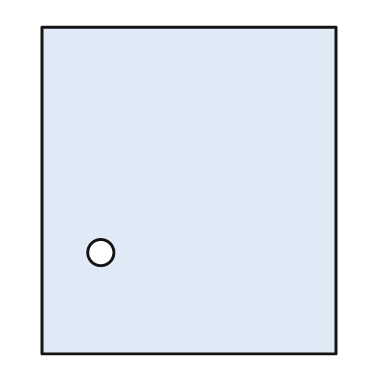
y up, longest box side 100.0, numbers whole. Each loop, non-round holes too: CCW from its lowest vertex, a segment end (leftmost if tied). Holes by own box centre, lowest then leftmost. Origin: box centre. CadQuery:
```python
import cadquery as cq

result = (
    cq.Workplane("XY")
    .moveTo(-45.0, -50.0)
    .lineTo(45.0, -50.0)
    .lineTo(45.0, 50.0)
    .lineTo(-45.0, 50.0)
    .close()
    .moveTo(-27.0, -19.0)
    .circle(4.0)
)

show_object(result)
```